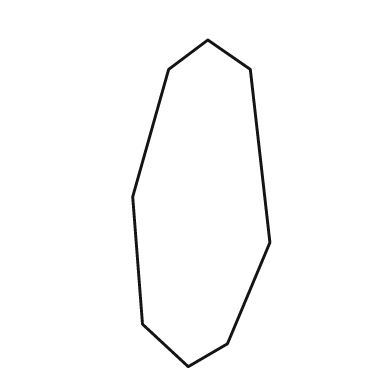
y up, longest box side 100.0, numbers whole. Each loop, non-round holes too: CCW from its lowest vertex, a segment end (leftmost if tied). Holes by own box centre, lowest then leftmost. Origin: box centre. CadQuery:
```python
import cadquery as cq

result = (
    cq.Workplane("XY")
    .moveTo(-4.0, -50.0)
    .lineTo(8.0, -43.0)
    .lineTo(21.0, -12.0)
    .lineTo(15.0, 41.0)
    .lineTo(2.0, 50.0)
    .lineTo(-10.0, 41.0)
    .lineTo(-21.0, 2.0)
    .lineTo(-18.0, -37.0)
    .close()
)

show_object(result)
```